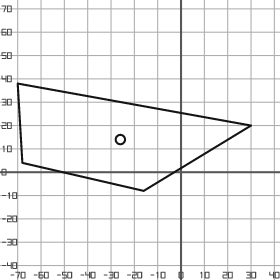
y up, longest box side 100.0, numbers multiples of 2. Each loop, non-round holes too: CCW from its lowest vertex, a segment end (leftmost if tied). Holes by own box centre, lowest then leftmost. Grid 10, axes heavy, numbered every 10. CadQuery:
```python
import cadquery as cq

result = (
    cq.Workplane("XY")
    .moveTo(-16.0, -8.0)
    .lineTo(30.0, 20.0)
    .lineTo(-70.0, 38.0)
    .lineTo(-68.0, 4.0)
    .close()
    .moveTo(-26.0, 14.0)
    .circle(2.0)
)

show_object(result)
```